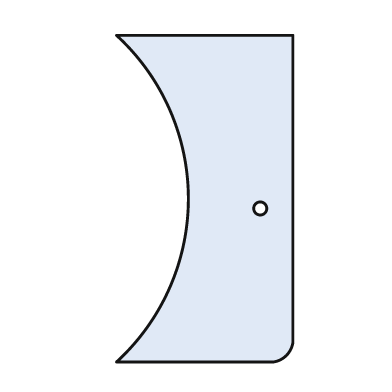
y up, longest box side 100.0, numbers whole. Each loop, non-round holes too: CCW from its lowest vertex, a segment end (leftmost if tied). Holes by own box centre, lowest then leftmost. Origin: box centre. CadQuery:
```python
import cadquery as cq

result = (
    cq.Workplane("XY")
    .moveTo(-27.0, -50.0)
    .lineTo(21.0, -50.0)
    .threePointArc((25.0, -48.0), (27.0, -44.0))
    .lineTo(27.0, 50.0)
    .lineTo(-27.0, 50.0)
    .threePointArc((-5.0, 0.0), (-27.0, -50.0))
    .close()
    .moveTo(17.0, -3.0)
    .circle(2.0)
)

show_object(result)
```